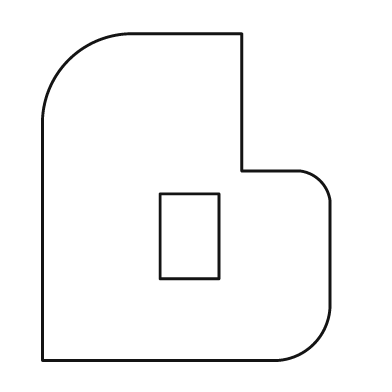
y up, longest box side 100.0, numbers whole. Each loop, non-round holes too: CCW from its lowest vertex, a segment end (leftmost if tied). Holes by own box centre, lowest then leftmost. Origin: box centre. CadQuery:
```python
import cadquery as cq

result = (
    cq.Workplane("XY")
    .moveTo(-44.0, -50.0)
    .lineTo(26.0, -50.0)
    .threePointArc((39.0, -45.0), (44.0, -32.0))
    .lineTo(44.0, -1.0)
    .threePointArc((41.0, 5.0), (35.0, 8.0))
    .lineTo(17.0, 8.0)
    .lineTo(17.0, 50.0)
    .lineTo(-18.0, 50.0)
    .threePointArc((-36.0, 42.0), (-44.0, 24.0))
    .close()
    .moveTo(-8.0, -25.0)
    .lineTo(10.0, -25.0)
    .lineTo(10.0, 1.0)
    .lineTo(-8.0, 1.0)
    .close()
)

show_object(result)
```